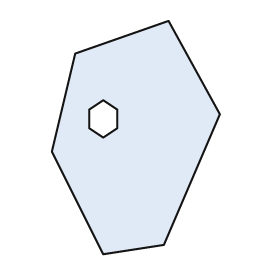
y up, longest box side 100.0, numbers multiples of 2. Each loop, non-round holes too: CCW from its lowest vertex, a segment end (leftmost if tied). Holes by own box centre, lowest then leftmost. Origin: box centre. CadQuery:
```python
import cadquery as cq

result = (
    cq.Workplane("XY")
    .moveTo(-14.0, -50.0)
    .lineTo(12.0, -46.0)
    .lineTo(36.0, 10.0)
    .lineTo(14.0, 50.0)
    .lineTo(-26.0, 36.0)
    .lineTo(-36.0, -6.0)
    .close()
    .moveTo(-14.0, 0.0)
    .lineTo(-8.0, 4.0)
    .lineTo(-8.0, 12.0)
    .lineTo(-14.0, 16.0)
    .lineTo(-20.0, 12.0)
    .lineTo(-20.0, 4.0)
    .close()
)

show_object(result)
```